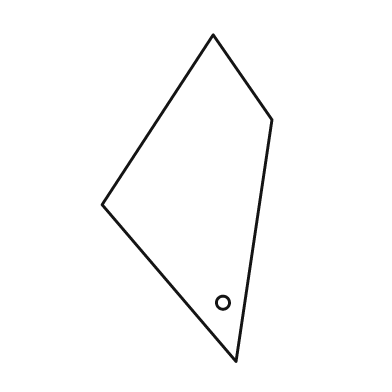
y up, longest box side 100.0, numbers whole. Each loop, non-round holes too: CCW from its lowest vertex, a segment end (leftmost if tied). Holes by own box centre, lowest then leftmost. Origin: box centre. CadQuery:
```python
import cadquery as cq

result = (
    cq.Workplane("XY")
    .moveTo(15.0, -50.0)
    .lineTo(26.0, 24.0)
    .lineTo(8.0, 50.0)
    .lineTo(-26.0, -2.0)
    .close()
    .moveTo(11.0, -32.0)
    .circle(2.0)
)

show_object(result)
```